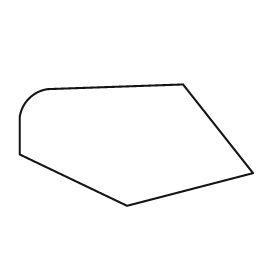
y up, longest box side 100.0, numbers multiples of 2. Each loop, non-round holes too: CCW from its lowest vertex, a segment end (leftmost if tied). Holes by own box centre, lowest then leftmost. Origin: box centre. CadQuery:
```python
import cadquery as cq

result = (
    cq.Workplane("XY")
    .moveTo(-4.0, -26.0)
    .lineTo(50.0, -12.0)
    .lineTo(20.0, 26.0)
    .lineTo(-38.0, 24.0)
    .threePointArc((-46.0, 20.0), (-50.0, 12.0))
    .lineTo(-50.0, -4.0)
    .close()
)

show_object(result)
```